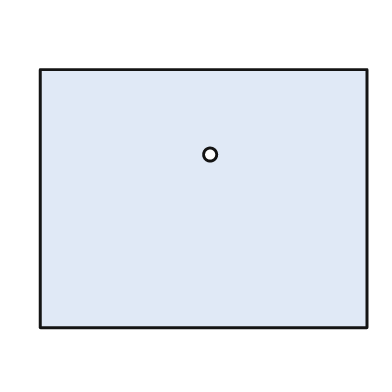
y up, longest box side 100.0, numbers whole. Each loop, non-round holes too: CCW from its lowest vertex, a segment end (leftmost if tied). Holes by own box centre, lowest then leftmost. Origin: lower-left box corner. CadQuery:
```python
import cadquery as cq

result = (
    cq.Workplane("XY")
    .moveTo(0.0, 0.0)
    .lineTo(100.0, 0.0)
    .lineTo(100.0, 79.0)
    .lineTo(0.0, 79.0)
    .close()
    .moveTo(52.0, 53.0)
    .circle(2.0)
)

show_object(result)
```